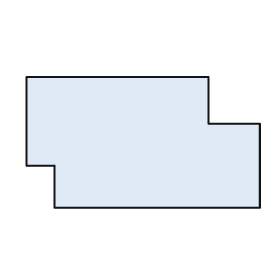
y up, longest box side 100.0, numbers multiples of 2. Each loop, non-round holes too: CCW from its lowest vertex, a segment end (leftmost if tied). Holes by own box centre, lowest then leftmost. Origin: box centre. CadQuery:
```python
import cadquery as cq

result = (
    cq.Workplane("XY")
    .moveTo(-38.0, -28.0)
    .lineTo(50.0, -28.0)
    .lineTo(50.0, 8.0)
    .lineTo(28.0, 8.0)
    .lineTo(28.0, 28.0)
    .lineTo(-50.0, 28.0)
    .lineTo(-50.0, -10.0)
    .lineTo(-38.0, -10.0)
    .close()
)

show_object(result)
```